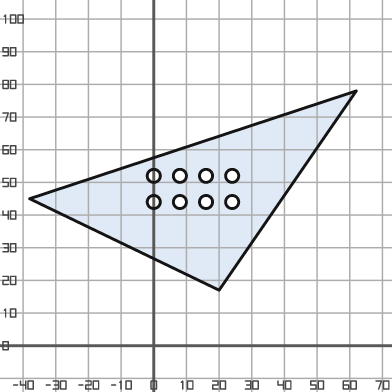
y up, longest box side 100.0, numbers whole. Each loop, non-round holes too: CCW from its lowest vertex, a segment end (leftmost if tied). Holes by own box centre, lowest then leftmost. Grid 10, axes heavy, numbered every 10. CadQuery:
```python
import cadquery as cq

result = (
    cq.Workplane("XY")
    .moveTo(20.0, 17.0)
    .lineTo(62.0, 78.0)
    .lineTo(-38.0, 45.0)
    .close()
    .moveTo(0.0, 44.0)
    .circle(2.0)
    .moveTo(8.0, 44.0)
    .circle(2.0)
    .moveTo(16.0, 44.0)
    .circle(2.0)
    .moveTo(24.0, 44.0)
    .circle(2.0)
    .moveTo(0.0, 52.0)
    .circle(2.0)
    .moveTo(8.0, 52.0)
    .circle(2.0)
    .moveTo(16.0, 52.0)
    .circle(2.0)
    .moveTo(24.0, 52.0)
    .circle(2.0)
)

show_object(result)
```